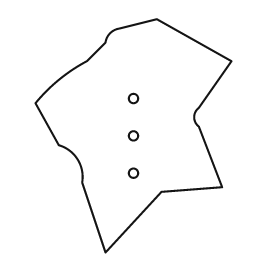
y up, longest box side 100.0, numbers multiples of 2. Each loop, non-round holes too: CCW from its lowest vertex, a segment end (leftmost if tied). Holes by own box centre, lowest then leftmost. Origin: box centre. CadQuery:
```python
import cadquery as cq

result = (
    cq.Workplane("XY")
    .moveTo(-12.0, -50.0)
    .lineTo(12.0, -24.0)
    .lineTo(38.0, -22.0)
    .lineTo(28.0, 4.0)
    .threePointArc((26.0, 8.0), (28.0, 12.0))
    .lineTo(42.0, 32.0)
    .lineTo(10.0, 50.0)
    .lineTo(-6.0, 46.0)
    .threePointArc((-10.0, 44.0), (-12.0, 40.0))
    .lineTo(-20.0, 32.0)
    .threePointArc((-32.0, 24.0), (-42.0, 14.0))
    .lineTo(-32.0, -4.0)
    .threePointArc((-24.0, -10.0), (-22.0, -20.0))
    .close()
    .moveTo(0.0, -16.0)
    .circle(2.0)
    .moveTo(0.0, 0.0)
    .circle(2.0)
    .moveTo(0.0, 16.0)
    .circle(2.0)
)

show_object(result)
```